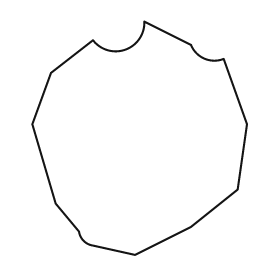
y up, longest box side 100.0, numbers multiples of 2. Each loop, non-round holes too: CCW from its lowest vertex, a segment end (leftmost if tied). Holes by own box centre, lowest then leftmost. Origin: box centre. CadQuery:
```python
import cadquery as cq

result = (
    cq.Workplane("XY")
    .moveTo(-2.0, -50.0)
    .lineTo(22.0, -38.0)
    .lineTo(42.0, -22.0)
    .lineTo(46.0, 6.0)
    .lineTo(36.0, 34.0)
    .threePointArc((28.0, 34.0), (22.0, 40.0))
    .lineTo(2.0, 50.0)
    .threePointArc((-6.0, 38.0), (-20.0, 42.0))
    .lineTo(-38.0, 28.0)
    .lineTo(-46.0, 6.0)
    .lineTo(-36.0, -28.0)
    .lineTo(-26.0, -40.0)
    .threePointArc((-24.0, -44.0), (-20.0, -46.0))
    .close()
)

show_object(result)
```